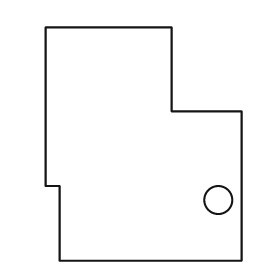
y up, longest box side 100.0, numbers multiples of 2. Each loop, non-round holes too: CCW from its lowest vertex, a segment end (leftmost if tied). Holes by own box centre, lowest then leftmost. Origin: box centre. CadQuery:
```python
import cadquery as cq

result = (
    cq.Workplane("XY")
    .moveTo(-36.0, -50.0)
    .lineTo(42.0, -50.0)
    .lineTo(42.0, 14.0)
    .lineTo(12.0, 14.0)
    .lineTo(12.0, 50.0)
    .lineTo(-42.0, 50.0)
    .lineTo(-42.0, -18.0)
    .lineTo(-36.0, -18.0)
    .close()
    .moveTo(32.0, -24.0)
    .circle(6.0)
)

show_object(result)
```